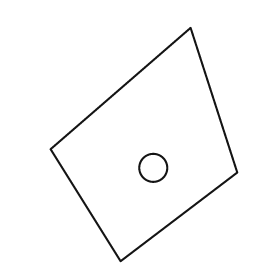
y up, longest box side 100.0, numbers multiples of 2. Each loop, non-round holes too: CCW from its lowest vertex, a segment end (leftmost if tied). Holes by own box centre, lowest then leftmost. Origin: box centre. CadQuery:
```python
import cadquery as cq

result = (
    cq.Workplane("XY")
    .moveTo(-10.0, -50.0)
    .lineTo(40.0, -12.0)
    .lineTo(20.0, 50.0)
    .lineTo(-40.0, -2.0)
    .close()
    .moveTo(4.0, -10.0)
    .circle(6.0)
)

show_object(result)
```